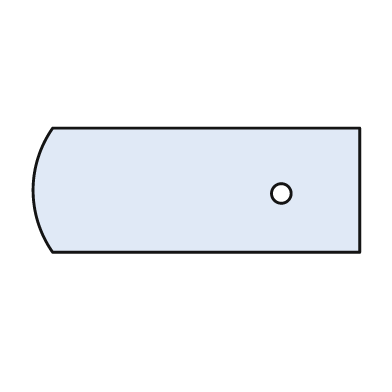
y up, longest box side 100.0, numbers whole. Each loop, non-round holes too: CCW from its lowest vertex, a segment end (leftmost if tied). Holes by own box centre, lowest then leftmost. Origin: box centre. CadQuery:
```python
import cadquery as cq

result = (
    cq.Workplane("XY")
    .moveTo(-44.0, -19.0)
    .lineTo(50.0, -19.0)
    .lineTo(50.0, 19.0)
    .lineTo(-44.0, 19.0)
    .threePointArc((-50.0, 0.0), (-44.0, -19.0))
    .close()
    .moveTo(26.0, -1.0)
    .circle(3.0)
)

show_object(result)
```